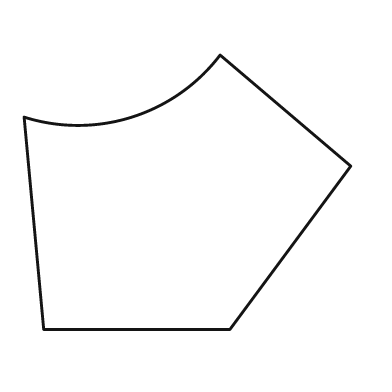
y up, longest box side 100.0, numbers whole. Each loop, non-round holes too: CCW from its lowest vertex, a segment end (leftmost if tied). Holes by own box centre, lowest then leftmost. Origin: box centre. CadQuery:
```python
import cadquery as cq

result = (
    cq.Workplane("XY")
    .moveTo(-44.0, -42.0)
    .lineTo(13.0, -42.0)
    .lineTo(50.0, 8.0)
    .lineTo(10.0, 42.0)
    .threePointArc((-17.0, 23.0), (-50.0, 23.0))
    .close()
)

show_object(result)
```